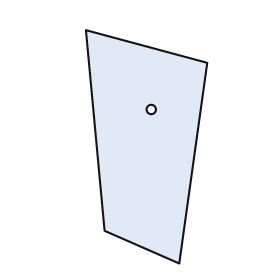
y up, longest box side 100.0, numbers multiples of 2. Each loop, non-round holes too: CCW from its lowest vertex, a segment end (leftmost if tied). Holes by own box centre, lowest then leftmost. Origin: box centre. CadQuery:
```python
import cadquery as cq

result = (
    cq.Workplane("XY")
    .moveTo(14.0, -50.0)
    .lineTo(26.0, 36.0)
    .lineTo(-26.0, 50.0)
    .lineTo(-18.0, -36.0)
    .close()
    .moveTo(2.0, 16.0)
    .circle(2.0)
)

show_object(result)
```